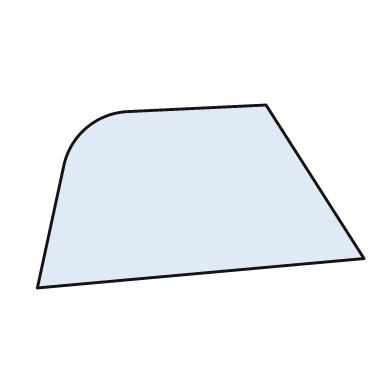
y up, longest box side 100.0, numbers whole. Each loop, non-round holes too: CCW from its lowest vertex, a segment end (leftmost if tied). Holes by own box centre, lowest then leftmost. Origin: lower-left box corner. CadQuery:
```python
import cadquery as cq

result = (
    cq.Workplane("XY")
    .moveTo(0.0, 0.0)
    .lineTo(100.0, 9.0)
    .lineTo(70.0, 56.0)
    .lineTo(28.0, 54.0)
    .threePointArc((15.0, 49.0), (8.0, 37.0))
    .close()
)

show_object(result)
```